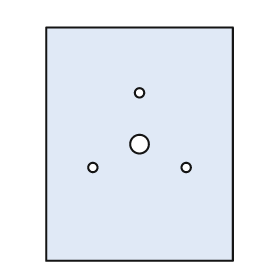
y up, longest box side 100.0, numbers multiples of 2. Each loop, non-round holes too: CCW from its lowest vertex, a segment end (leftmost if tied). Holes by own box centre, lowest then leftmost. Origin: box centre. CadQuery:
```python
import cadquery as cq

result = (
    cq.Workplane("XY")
    .moveTo(-40.0, -50.0)
    .lineTo(40.0, -50.0)
    .lineTo(40.0, 50.0)
    .lineTo(-40.0, 50.0)
    .close()
    .moveTo(-20.0, -10.0)
    .circle(2.0)
    .moveTo(20.0, -10.0)
    .circle(2.0)
    .moveTo(0.0, 0.0)
    .circle(4.0)
    .moveTo(0.0, 22.0)
    .circle(2.0)
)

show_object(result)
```